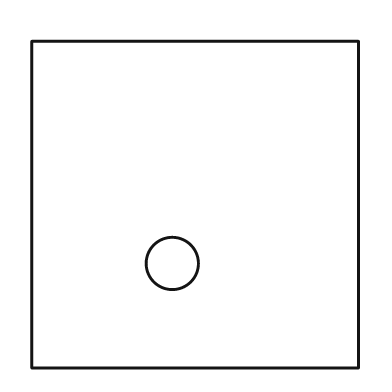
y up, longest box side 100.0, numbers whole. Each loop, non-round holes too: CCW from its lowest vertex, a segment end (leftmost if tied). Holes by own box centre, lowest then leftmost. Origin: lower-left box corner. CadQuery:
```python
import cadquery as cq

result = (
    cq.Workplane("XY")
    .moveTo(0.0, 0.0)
    .lineTo(100.0, 0.0)
    .lineTo(100.0, 100.0)
    .lineTo(0.0, 100.0)
    .close()
    .moveTo(43.0, 32.0)
    .circle(8.0)
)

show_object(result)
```